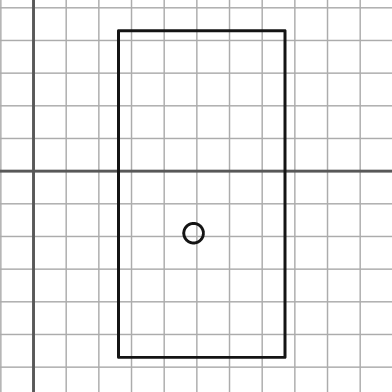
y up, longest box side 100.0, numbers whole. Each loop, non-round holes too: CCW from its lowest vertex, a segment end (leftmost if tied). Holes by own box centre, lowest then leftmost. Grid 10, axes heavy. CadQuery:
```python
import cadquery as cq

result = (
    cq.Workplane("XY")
    .moveTo(26.0, -57.0)
    .lineTo(77.0, -57.0)
    .lineTo(77.0, 43.0)
    .lineTo(26.0, 43.0)
    .close()
    .moveTo(49.0, -19.0)
    .circle(3.0)
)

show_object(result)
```